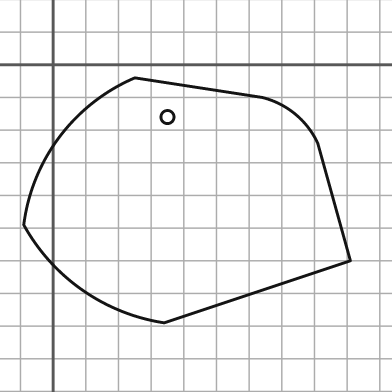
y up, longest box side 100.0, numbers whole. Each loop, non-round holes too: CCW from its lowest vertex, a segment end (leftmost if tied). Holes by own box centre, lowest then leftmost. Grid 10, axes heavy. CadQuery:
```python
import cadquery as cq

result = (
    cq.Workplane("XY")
    .moveTo(34.0, -79.0)
    .lineTo(91.0, -60.0)
    .lineTo(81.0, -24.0)
    .threePointArc((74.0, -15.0), (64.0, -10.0))
    .lineTo(25.0, -4.0)
    .threePointArc((2.0, -22.0), (-9.0, -49.0))
    .threePointArc((9.0, -69.0), (34.0, -79.0))
    .close()
    .moveTo(35.0, -16.0)
    .circle(2.0)
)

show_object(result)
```